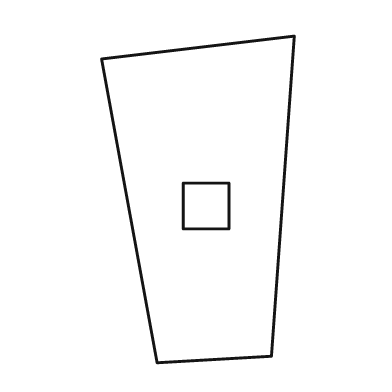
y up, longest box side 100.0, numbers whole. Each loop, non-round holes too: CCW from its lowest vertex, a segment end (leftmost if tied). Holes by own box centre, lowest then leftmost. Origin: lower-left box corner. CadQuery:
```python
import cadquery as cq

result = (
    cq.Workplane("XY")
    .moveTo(17.0, 0.0)
    .lineTo(52.0, 2.0)
    .lineTo(59.0, 100.0)
    .lineTo(0.0, 93.0)
    .close()
    .moveTo(25.0, 41.0)
    .lineTo(39.0, 41.0)
    .lineTo(39.0, 55.0)
    .lineTo(25.0, 55.0)
    .close()
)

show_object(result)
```